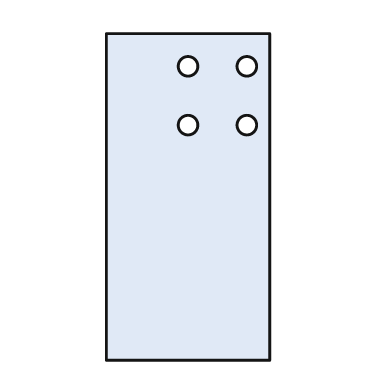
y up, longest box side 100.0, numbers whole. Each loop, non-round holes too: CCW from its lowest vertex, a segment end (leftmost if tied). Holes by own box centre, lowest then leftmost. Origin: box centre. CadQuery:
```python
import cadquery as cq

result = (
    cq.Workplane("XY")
    .moveTo(-25.0, -50.0)
    .lineTo(25.0, -50.0)
    .lineTo(25.0, 50.0)
    .lineTo(-25.0, 50.0)
    .close()
    .moveTo(0.0, 22.0)
    .circle(3.0)
    .moveTo(18.0, 22.0)
    .circle(3.0)
    .moveTo(0.0, 40.0)
    .circle(3.0)
    .moveTo(18.0, 40.0)
    .circle(3.0)
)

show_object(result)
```